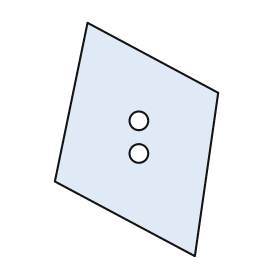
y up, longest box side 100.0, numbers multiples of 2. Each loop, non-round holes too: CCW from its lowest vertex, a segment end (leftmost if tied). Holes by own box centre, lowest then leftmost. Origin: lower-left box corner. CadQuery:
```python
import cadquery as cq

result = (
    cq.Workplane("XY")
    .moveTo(60.0, 0.0)
    .lineTo(70.0, 70.0)
    .lineTo(14.0, 100.0)
    .lineTo(0.0, 32.0)
    .close()
    .moveTo(36.0, 44.0)
    .circle(4.0)
    .moveTo(36.0, 58.0)
    .circle(4.0)
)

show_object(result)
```